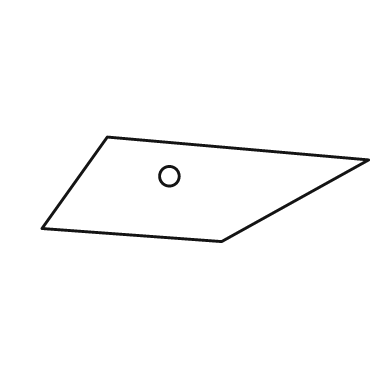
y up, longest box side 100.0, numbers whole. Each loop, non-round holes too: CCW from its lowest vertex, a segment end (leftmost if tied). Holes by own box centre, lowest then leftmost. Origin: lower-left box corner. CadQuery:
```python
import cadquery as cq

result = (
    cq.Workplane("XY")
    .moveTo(55.0, 0.0)
    .lineTo(100.0, 25.0)
    .lineTo(20.0, 32.0)
    .lineTo(0.0, 4.0)
    .close()
    .moveTo(39.0, 20.0)
    .circle(3.0)
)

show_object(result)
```